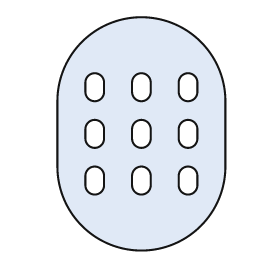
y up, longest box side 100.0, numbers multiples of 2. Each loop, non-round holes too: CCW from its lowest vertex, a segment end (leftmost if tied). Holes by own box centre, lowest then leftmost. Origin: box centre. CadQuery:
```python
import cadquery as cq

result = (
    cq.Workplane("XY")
    .moveTo(-36.0, -14.0)
    .threePointArc((0.0, -50.0), (36.0, -14.0))
    .lineTo(36.0, 14.0)
    .threePointArc((0.0, 50.0), (-36.0, 14.0))
    .close()
    .moveTo(-24.0, -22.0)
    .threePointArc((-20.0, -26.0), (-16.0, -22.0))
    .lineTo(-16.0, -18.0)
    .threePointArc((-20.0, -14.0), (-24.0, -18.0))
    .close()
    .moveTo(-4.0, -22.0)
    .threePointArc((0.0, -26.0), (4.0, -22.0))
    .lineTo(4.0, -18.0)
    .threePointArc((0.0, -14.0), (-4.0, -18.0))
    .close()
    .moveTo(16.0, -22.0)
    .threePointArc((20.0, -26.0), (24.0, -22.0))
    .lineTo(24.0, -18.0)
    .threePointArc((20.0, -14.0), (16.0, -18.0))
    .close()
    .moveTo(-24.0, -2.0)
    .threePointArc((-20.0, -6.0), (-16.0, -2.0))
    .lineTo(-16.0, 2.0)
    .threePointArc((-20.0, 6.0), (-24.0, 2.0))
    .close()
    .moveTo(-4.0, -2.0)
    .threePointArc((0.0, -6.0), (4.0, -2.0))
    .lineTo(4.0, 2.0)
    .threePointArc((0.0, 6.0), (-4.0, 2.0))
    .close()
    .moveTo(16.0, -2.0)
    .threePointArc((20.0, -6.0), (24.0, -2.0))
    .lineTo(24.0, 2.0)
    .threePointArc((20.0, 6.0), (16.0, 2.0))
    .close()
    .moveTo(-24.0, 18.0)
    .threePointArc((-20.0, 14.0), (-16.0, 18.0))
    .lineTo(-16.0, 22.0)
    .threePointArc((-20.0, 26.0), (-24.0, 22.0))
    .close()
    .moveTo(-4.0, 18.0)
    .threePointArc((0.0, 14.0), (4.0, 18.0))
    .lineTo(4.0, 22.0)
    .threePointArc((0.0, 26.0), (-4.0, 22.0))
    .close()
    .moveTo(16.0, 18.0)
    .threePointArc((20.0, 14.0), (24.0, 18.0))
    .lineTo(24.0, 22.0)
    .threePointArc((20.0, 26.0), (16.0, 22.0))
    .close()
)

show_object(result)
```